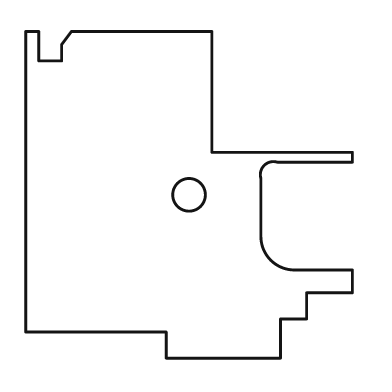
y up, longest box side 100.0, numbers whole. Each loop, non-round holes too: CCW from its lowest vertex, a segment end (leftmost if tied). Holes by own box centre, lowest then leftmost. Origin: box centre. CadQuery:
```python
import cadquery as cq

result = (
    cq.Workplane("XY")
    .moveTo(-7.0, -50.0)
    .lineTo(28.0, -50.0)
    .lineTo(28.0, -38.0)
    .lineTo(36.0, -38.0)
    .lineTo(36.0, -30.0)
    .lineTo(50.0, -30.0)
    .lineTo(50.0, -23.0)
    .lineTo(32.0, -23.0)
    .threePointArc((25.0, -20.0), (22.0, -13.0))
    .lineTo(22.0, 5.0)
    .threePointArc((23.0, 9.0), (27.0, 10.0))
    .lineTo(50.0, 10.0)
    .lineTo(50.0, 13.0)
    .lineTo(7.0, 13.0)
    .lineTo(7.0, 50.0)
    .lineTo(-36.0, 50.0)
    .lineTo(-39.0, 46.0)
    .lineTo(-39.0, 41.0)
    .lineTo(-46.0, 41.0)
    .lineTo(-46.0, 50.0)
    .lineTo(-50.0, 50.0)
    .lineTo(-50.0, -42.0)
    .lineTo(-7.0, -42.0)
    .close()
    .moveTo(0.0, 0.0)
    .circle(5.0)
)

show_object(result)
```